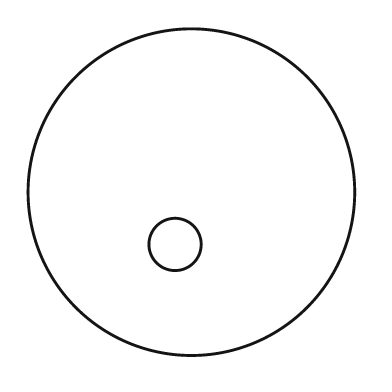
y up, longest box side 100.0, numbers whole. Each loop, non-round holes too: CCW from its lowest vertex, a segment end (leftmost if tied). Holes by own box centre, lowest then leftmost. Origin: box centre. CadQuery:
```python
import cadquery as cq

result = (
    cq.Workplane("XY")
    .moveTo(0.0, 0.0)
    .circle(50.0)
    .moveTo(-5.0, -16.0)
    .circle(8.0)
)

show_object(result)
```